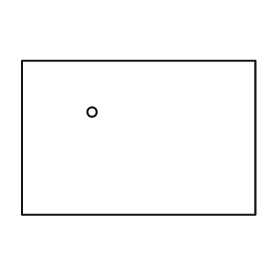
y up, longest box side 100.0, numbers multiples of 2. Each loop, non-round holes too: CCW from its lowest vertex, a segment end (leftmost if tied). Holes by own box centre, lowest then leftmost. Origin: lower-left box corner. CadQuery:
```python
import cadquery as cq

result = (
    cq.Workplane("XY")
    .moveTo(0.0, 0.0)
    .lineTo(100.0, 0.0)
    .lineTo(100.0, 66.0)
    .lineTo(0.0, 66.0)
    .close()
    .moveTo(30.0, 44.0)
    .circle(2.0)
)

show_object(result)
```